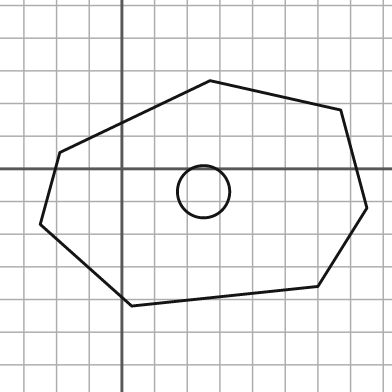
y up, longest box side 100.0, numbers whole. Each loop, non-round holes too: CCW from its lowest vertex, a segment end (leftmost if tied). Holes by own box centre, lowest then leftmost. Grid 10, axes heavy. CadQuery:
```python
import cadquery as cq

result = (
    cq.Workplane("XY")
    .moveTo(3.0, -42.0)
    .lineTo(60.0, -36.0)
    .lineTo(75.0, -12.0)
    .lineTo(67.0, 18.0)
    .lineTo(27.0, 27.0)
    .lineTo(-19.0, 5.0)
    .lineTo(-25.0, -17.0)
    .close()
    .moveTo(25.0, -7.0)
    .circle(8.0)
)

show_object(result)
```